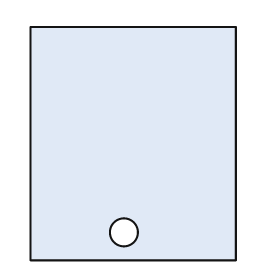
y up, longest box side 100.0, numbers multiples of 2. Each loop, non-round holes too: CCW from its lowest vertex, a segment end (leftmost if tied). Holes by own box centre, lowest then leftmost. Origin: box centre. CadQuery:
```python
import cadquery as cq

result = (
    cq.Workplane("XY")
    .moveTo(-44.0, -50.0)
    .lineTo(44.0, -50.0)
    .lineTo(44.0, 50.0)
    .lineTo(-44.0, 50.0)
    .close()
    .moveTo(-4.0, -38.0)
    .circle(6.0)
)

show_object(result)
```